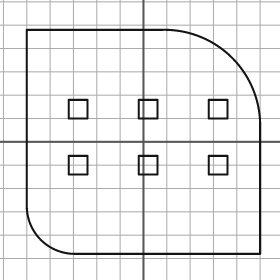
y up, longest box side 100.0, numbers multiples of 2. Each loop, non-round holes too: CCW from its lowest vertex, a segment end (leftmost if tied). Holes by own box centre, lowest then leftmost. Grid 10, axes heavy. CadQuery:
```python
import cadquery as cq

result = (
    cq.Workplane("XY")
    .moveTo(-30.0, -48.0)
    .lineTo(50.0, -48.0)
    .lineTo(50.0, 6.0)
    .threePointArc((38.0, 36.0), (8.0, 48.0))
    .lineTo(-50.0, 48.0)
    .lineTo(-50.0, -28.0)
    .threePointArc((-44.0, -42.0), (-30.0, -48.0))
    .close()
    .moveTo(-32.0, -14.0)
    .lineTo(-24.0, -14.0)
    .lineTo(-24.0, -6.0)
    .lineTo(-32.0, -6.0)
    .close()
    .moveTo(-2.0, -14.0)
    .lineTo(6.0, -14.0)
    .lineTo(6.0, -6.0)
    .lineTo(-2.0, -6.0)
    .close()
    .moveTo(28.0, -14.0)
    .lineTo(36.0, -14.0)
    .lineTo(36.0, -6.0)
    .lineTo(28.0, -6.0)
    .close()
    .moveTo(-32.0, 10.0)
    .lineTo(-24.0, 10.0)
    .lineTo(-24.0, 18.0)
    .lineTo(-32.0, 18.0)
    .close()
    .moveTo(-2.0, 10.0)
    .lineTo(6.0, 10.0)
    .lineTo(6.0, 18.0)
    .lineTo(-2.0, 18.0)
    .close()
    .moveTo(28.0, 10.0)
    .lineTo(36.0, 10.0)
    .lineTo(36.0, 18.0)
    .lineTo(28.0, 18.0)
    .close()
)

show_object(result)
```